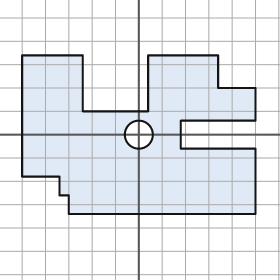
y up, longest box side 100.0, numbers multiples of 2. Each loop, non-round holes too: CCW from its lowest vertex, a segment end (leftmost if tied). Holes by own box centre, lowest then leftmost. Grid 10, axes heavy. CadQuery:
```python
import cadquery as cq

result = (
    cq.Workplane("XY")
    .moveTo(-30.0, -34.0)
    .lineTo(50.0, -34.0)
    .lineTo(50.0, -6.0)
    .lineTo(18.0, -6.0)
    .lineTo(18.0, 6.0)
    .lineTo(50.0, 6.0)
    .lineTo(50.0, 20.0)
    .lineTo(34.0, 20.0)
    .lineTo(34.0, 34.0)
    .lineTo(4.0, 34.0)
    .lineTo(4.0, 10.0)
    .lineTo(-24.0, 10.0)
    .lineTo(-24.0, 34.0)
    .lineTo(-50.0, 34.0)
    .lineTo(-50.0, -18.0)
    .lineTo(-34.0, -18.0)
    .lineTo(-34.0, -26.0)
    .lineTo(-30.0, -26.0)
    .close()
    .moveTo(0.0, 0.0)
    .circle(6.0)
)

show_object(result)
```